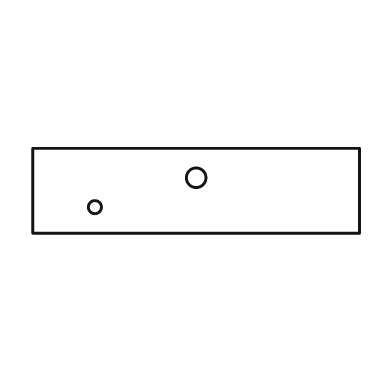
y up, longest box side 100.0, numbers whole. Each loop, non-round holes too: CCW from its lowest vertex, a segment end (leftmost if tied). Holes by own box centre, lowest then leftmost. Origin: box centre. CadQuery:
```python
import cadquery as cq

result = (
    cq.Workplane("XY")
    .moveTo(-50.0, -13.0)
    .lineTo(50.0, -13.0)
    .lineTo(50.0, 13.0)
    .lineTo(-50.0, 13.0)
    .close()
    .moveTo(-31.0, -5.0)
    .circle(2.0)
    .moveTo(0.0, 4.0)
    .circle(3.0)
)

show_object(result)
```